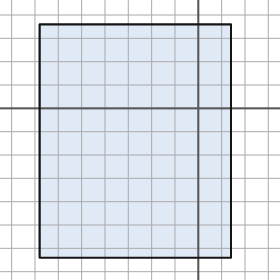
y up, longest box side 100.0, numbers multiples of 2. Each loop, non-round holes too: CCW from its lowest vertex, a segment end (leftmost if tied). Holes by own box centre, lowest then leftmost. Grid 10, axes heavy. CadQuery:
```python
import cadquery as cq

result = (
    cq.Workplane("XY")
    .moveTo(-68.0, -64.0)
    .lineTo(14.0, -64.0)
    .lineTo(14.0, 36.0)
    .lineTo(-68.0, 36.0)
    .close()
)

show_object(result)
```